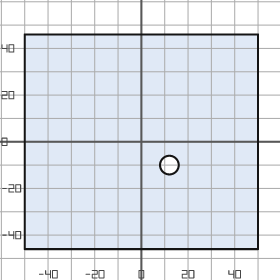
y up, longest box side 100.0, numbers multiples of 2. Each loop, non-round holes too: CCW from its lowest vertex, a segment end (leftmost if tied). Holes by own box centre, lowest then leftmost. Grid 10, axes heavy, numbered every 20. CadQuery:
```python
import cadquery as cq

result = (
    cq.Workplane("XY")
    .moveTo(-50.0, -46.0)
    .lineTo(50.0, -46.0)
    .lineTo(50.0, 46.0)
    .lineTo(-50.0, 46.0)
    .close()
    .moveTo(12.0, -10.0)
    .circle(4.0)
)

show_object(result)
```